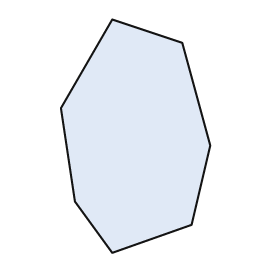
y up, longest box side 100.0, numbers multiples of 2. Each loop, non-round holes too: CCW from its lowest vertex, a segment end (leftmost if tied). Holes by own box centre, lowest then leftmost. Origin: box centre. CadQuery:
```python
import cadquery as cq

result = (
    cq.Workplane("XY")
    .moveTo(-10.0, -50.0)
    .lineTo(24.0, -38.0)
    .lineTo(32.0, -4.0)
    .lineTo(20.0, 40.0)
    .lineTo(-10.0, 50.0)
    .lineTo(-32.0, 12.0)
    .lineTo(-26.0, -28.0)
    .close()
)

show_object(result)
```